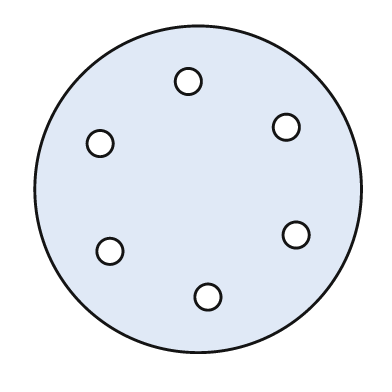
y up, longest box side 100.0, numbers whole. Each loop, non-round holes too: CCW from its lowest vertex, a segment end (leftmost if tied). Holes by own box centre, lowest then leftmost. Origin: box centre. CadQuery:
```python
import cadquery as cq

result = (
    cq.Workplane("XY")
    .moveTo(0.0, 0.0)
    .circle(50.0)
    .moveTo(3.0, -33.0)
    .circle(4.0)
    .moveTo(-27.0, -19.0)
    .circle(4.0)
    .moveTo(30.0, -14.0)
    .circle(4.0)
    .moveTo(-30.0, 14.0)
    .circle(4.0)
    .moveTo(27.0, 19.0)
    .circle(4.0)
    .moveTo(-3.0, 33.0)
    .circle(4.0)
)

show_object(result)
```